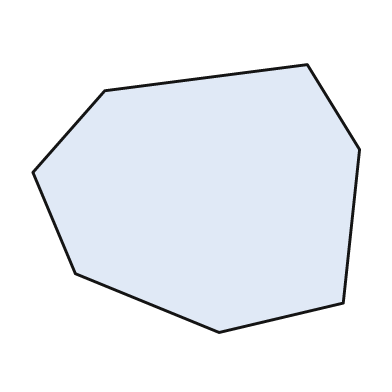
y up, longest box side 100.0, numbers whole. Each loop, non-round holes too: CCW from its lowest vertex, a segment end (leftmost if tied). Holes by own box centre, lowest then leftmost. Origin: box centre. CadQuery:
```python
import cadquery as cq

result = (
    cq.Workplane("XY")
    .moveTo(7.0, -41.0)
    .lineTo(45.0, -32.0)
    .lineTo(50.0, 15.0)
    .lineTo(34.0, 41.0)
    .lineTo(-28.0, 33.0)
    .lineTo(-50.0, 8.0)
    .lineTo(-37.0, -23.0)
    .close()
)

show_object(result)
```